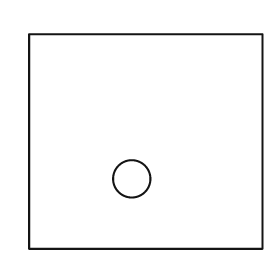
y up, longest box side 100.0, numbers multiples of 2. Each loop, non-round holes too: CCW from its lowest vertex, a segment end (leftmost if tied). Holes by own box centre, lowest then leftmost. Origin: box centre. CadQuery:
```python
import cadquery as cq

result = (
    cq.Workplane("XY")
    .moveTo(-50.0, -46.0)
    .lineTo(50.0, -46.0)
    .lineTo(50.0, 46.0)
    .lineTo(-50.0, 46.0)
    .close()
    .moveTo(-6.0, -16.0)
    .circle(8.0)
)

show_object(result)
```